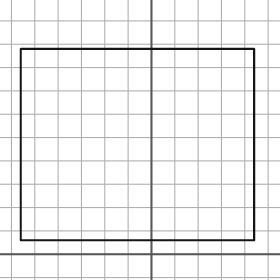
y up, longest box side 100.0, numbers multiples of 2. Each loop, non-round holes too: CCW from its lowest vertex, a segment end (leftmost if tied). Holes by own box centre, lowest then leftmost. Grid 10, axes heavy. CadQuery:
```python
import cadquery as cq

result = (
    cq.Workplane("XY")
    .moveTo(-56.0, 6.0)
    .lineTo(44.0, 6.0)
    .lineTo(44.0, 88.0)
    .lineTo(-56.0, 88.0)
    .close()
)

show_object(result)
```